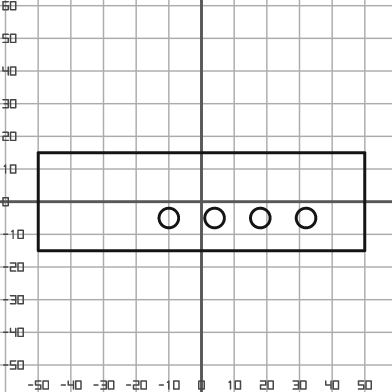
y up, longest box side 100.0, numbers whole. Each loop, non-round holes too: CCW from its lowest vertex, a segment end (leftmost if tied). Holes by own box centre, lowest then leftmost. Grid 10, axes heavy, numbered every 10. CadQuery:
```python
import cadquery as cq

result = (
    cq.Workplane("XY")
    .moveTo(-50.0, -15.0)
    .lineTo(50.0, -15.0)
    .lineTo(50.0, 15.0)
    .lineTo(-50.0, 15.0)
    .close()
    .moveTo(-10.0, -5.0)
    .circle(3.0)
    .moveTo(4.0, -5.0)
    .circle(3.0)
    .moveTo(18.0, -5.0)
    .circle(3.0)
    .moveTo(32.0, -5.0)
    .circle(3.0)
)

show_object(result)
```